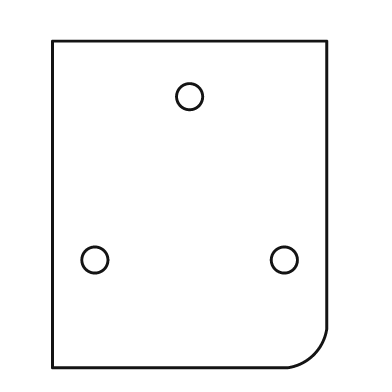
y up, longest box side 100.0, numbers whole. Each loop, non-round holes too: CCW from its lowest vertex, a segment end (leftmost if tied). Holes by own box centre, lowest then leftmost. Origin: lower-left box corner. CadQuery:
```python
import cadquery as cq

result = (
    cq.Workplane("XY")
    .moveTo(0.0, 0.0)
    .lineTo(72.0, 0.0)
    .threePointArc((80.0, 4.0), (84.0, 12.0))
    .lineTo(84.0, 100.0)
    .lineTo(0.0, 100.0)
    .close()
    .moveTo(13.0, 33.0)
    .circle(4.0)
    .moveTo(71.0, 33.0)
    .circle(4.0)
    .moveTo(42.0, 83.0)
    .circle(4.0)
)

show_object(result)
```